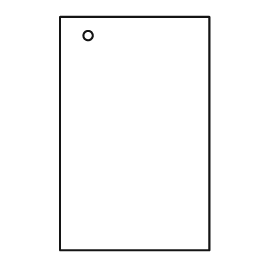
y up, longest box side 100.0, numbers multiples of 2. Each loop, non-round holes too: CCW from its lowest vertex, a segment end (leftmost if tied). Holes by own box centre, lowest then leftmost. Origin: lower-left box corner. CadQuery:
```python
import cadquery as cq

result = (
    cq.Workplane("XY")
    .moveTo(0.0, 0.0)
    .lineTo(64.0, 0.0)
    .lineTo(64.0, 100.0)
    .lineTo(0.0, 100.0)
    .close()
    .moveTo(12.0, 92.0)
    .circle(2.0)
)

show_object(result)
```